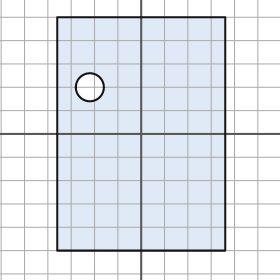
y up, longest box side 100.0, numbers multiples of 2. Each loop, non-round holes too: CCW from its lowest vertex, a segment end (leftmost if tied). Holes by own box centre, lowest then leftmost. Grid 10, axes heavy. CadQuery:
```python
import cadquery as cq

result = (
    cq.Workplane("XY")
    .moveTo(-36.0, -50.0)
    .lineTo(36.0, -50.0)
    .lineTo(36.0, 50.0)
    .lineTo(-36.0, 50.0)
    .close()
    .moveTo(-22.0, 20.0)
    .circle(6.0)
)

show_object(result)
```